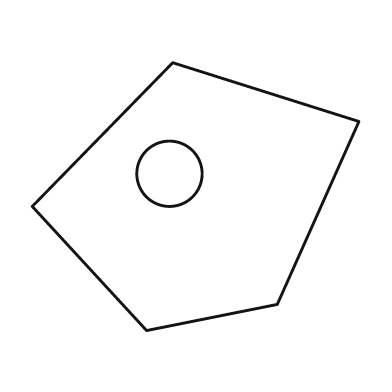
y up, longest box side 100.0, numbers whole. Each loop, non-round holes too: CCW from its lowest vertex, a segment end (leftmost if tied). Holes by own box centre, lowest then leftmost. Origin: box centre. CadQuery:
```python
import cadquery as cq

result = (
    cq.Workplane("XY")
    .moveTo(-15.0, -41.0)
    .lineTo(25.0, -33.0)
    .lineTo(50.0, 23.0)
    .lineTo(-7.0, 41.0)
    .lineTo(-50.0, -3.0)
    .close()
    .moveTo(-8.0, 7.0)
    .circle(10.0)
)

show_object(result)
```